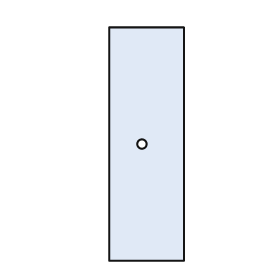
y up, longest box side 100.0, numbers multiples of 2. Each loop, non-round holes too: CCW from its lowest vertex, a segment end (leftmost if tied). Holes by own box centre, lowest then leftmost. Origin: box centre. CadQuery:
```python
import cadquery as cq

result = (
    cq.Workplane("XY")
    .moveTo(-16.0, -50.0)
    .lineTo(16.0, -50.0)
    .lineTo(16.0, 50.0)
    .lineTo(-16.0, 50.0)
    .close()
    .moveTo(-2.0, 0.0)
    .circle(2.0)
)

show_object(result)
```